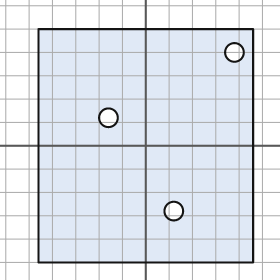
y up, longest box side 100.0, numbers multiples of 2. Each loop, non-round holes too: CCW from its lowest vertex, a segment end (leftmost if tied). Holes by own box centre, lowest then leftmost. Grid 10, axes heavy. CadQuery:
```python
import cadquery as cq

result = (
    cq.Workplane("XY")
    .moveTo(-46.0, -50.0)
    .lineTo(46.0, -50.0)
    .lineTo(46.0, 50.0)
    .lineTo(-46.0, 50.0)
    .close()
    .moveTo(12.0, -28.0)
    .circle(4.0)
    .moveTo(-16.0, 12.0)
    .circle(4.0)
    .moveTo(38.0, 40.0)
    .circle(4.0)
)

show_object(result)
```